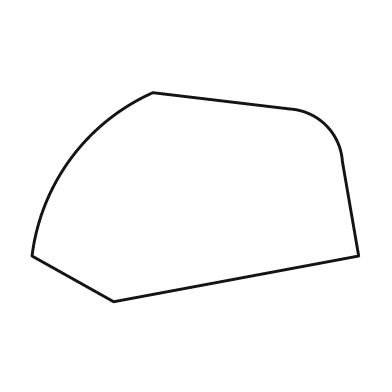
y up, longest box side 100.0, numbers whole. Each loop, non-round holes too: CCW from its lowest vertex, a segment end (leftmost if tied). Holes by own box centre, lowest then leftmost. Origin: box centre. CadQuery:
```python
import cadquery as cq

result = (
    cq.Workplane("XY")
    .moveTo(-25.0, -32.0)
    .lineTo(50.0, -18.0)
    .lineTo(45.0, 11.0)
    .threePointArc((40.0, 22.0), (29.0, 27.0))
    .lineTo(-13.0, 32.0)
    .threePointArc((-38.0, 12.0), (-50.0, -18.0))
    .close()
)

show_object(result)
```